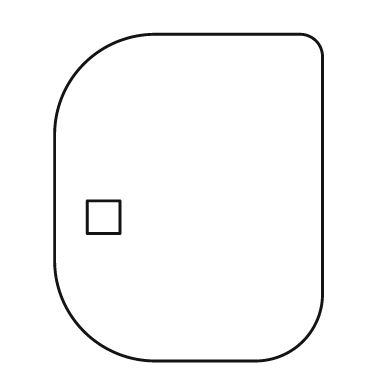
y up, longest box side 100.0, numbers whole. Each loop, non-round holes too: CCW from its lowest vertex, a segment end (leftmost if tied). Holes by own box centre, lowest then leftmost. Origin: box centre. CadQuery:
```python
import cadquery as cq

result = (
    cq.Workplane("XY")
    .moveTo(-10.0, -50.0)
    .lineTo(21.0, -50.0)
    .threePointArc((35.0, -44.0), (41.0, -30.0))
    .lineTo(41.0, 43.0)
    .threePointArc((39.0, 48.0), (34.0, 50.0))
    .lineTo(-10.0, 50.0)
    .threePointArc((-32.0, 41.0), (-41.0, 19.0))
    .lineTo(-41.0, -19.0)
    .threePointArc((-32.0, -41.0), (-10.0, -50.0))
    .close()
    .moveTo(-31.0, -11.0)
    .lineTo(-21.0, -11.0)
    .lineTo(-21.0, -1.0)
    .lineTo(-31.0, -1.0)
    .close()
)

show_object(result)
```